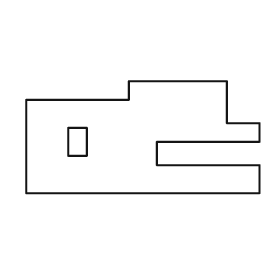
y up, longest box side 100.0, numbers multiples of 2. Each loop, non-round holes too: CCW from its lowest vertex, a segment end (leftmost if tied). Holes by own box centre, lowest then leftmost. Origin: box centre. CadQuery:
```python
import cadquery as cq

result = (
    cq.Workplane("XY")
    .moveTo(-50.0, -24.0)
    .lineTo(50.0, -24.0)
    .lineTo(50.0, -12.0)
    .lineTo(6.0, -12.0)
    .lineTo(6.0, -2.0)
    .lineTo(50.0, -2.0)
    .lineTo(50.0, 6.0)
    .lineTo(36.0, 6.0)
    .lineTo(36.0, 24.0)
    .lineTo(-6.0, 24.0)
    .lineTo(-6.0, 16.0)
    .lineTo(-50.0, 16.0)
    .close()
    .moveTo(-32.0, -8.0)
    .lineTo(-24.0, -8.0)
    .lineTo(-24.0, 4.0)
    .lineTo(-32.0, 4.0)
    .close()
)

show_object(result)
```